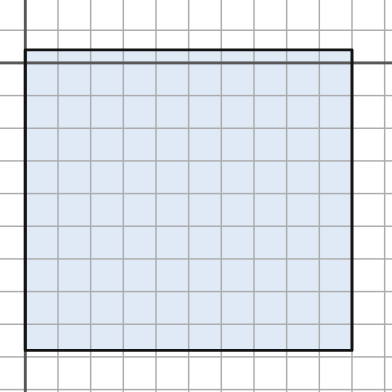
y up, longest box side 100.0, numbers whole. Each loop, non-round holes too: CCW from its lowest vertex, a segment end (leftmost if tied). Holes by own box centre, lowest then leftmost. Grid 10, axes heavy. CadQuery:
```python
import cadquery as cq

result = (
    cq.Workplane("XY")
    .moveTo(0.0, -88.0)
    .lineTo(100.0, -88.0)
    .lineTo(100.0, 4.0)
    .lineTo(0.0, 4.0)
    .close()
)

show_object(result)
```